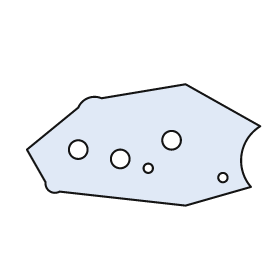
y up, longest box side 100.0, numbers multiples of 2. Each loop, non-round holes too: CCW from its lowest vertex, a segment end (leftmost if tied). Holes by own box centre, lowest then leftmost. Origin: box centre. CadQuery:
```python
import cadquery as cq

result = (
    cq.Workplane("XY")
    .moveTo(18.0, -26.0)
    .lineTo(46.0, -18.0)
    .threePointArc((42.0, -4.0), (50.0, 8.0))
    .lineTo(18.0, 26.0)
    .lineTo(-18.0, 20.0)
    .threePointArc((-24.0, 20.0), (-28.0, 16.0))
    .lineTo(-50.0, -2.0)
    .lineTo(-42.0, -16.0)
    .threePointArc((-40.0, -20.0), (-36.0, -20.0))
    .close()
    .moveTo(34.0, -14.0)
    .circle(2.0)
    .moveTo(2.0, -10.0)
    .circle(2.0)
    .moveTo(-10.0, -6.0)
    .circle(4.0)
    .moveTo(-28.0, -2.0)
    .circle(4.0)
    .moveTo(12.0, 2.0)
    .circle(4.0)
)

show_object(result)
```